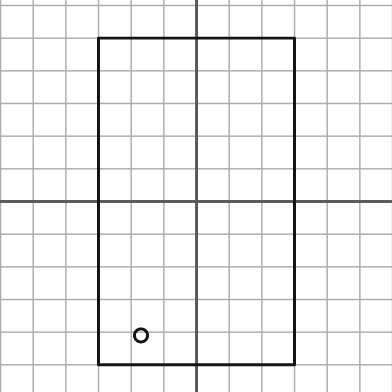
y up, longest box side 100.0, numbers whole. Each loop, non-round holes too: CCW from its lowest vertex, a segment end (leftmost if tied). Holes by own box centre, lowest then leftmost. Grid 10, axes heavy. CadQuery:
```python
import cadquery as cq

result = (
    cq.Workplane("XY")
    .moveTo(-30.0, -50.0)
    .lineTo(30.0, -50.0)
    .lineTo(30.0, 50.0)
    .lineTo(-30.0, 50.0)
    .close()
    .moveTo(-17.0, -41.0)
    .circle(2.0)
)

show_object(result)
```